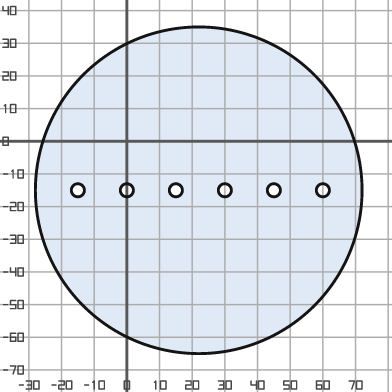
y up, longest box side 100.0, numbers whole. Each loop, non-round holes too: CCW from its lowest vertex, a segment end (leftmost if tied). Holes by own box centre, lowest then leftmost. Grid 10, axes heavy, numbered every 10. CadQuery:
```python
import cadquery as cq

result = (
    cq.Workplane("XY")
    .moveTo(22.0, -15.0)
    .circle(50.0)
    .moveTo(-15.0, -15.0)
    .circle(2.0)
    .moveTo(0.0, -15.0)
    .circle(2.0)
    .moveTo(15.0, -15.0)
    .circle(2.0)
    .moveTo(30.0, -15.0)
    .circle(2.0)
    .moveTo(45.0, -15.0)
    .circle(2.0)
    .moveTo(60.0, -15.0)
    .circle(2.0)
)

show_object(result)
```